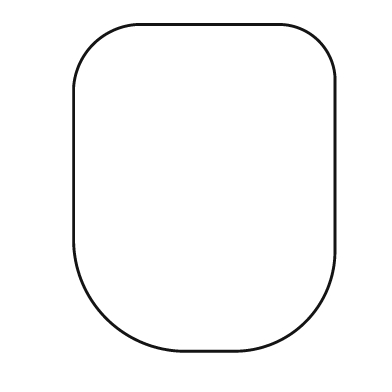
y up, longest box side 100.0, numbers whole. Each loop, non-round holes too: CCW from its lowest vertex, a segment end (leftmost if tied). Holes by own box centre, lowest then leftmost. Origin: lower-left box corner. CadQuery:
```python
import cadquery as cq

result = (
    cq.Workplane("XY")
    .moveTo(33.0, 0.0)
    .lineTo(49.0, 0.0)
    .threePointArc((71.0, 9.0), (80.0, 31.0))
    .lineTo(80.0, 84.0)
    .threePointArc((75.0, 95.0), (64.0, 100.0))
    .lineTo(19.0, 100.0)
    .threePointArc((6.0, 94.0), (0.0, 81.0))
    .lineTo(0.0, 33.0)
    .threePointArc((10.0, 10.0), (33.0, 0.0))
    .close()
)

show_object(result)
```